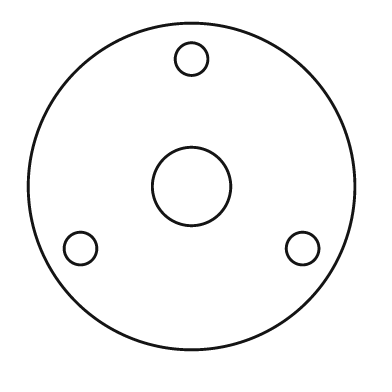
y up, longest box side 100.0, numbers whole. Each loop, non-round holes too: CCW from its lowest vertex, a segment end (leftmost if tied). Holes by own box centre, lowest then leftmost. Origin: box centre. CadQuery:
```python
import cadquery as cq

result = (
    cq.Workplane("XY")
    .moveTo(0.0, 0.0)
    .circle(50.0)
    .moveTo(-34.0, -19.0)
    .circle(5.0)
    .moveTo(34.0, -19.0)
    .circle(5.0)
    .moveTo(0.0, 0.0)
    .circle(12.0)
    .moveTo(0.0, 39.0)
    .circle(5.0)
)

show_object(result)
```